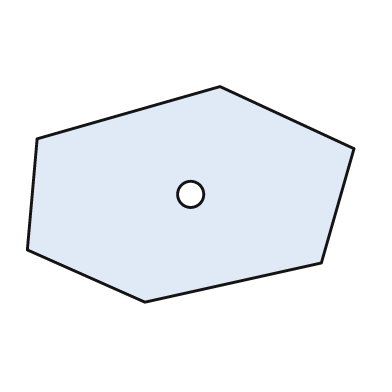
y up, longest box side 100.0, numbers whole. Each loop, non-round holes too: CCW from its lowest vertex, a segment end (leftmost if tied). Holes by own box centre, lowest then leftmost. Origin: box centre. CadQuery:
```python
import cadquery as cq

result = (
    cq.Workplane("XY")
    .moveTo(-14.0, -33.0)
    .lineTo(40.0, -21.0)
    .lineTo(50.0, 14.0)
    .lineTo(9.0, 33.0)
    .lineTo(-47.0, 17.0)
    .lineTo(-50.0, -17.0)
    .close()
    .moveTo(0.0, 0.0)
    .circle(4.0)
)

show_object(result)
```